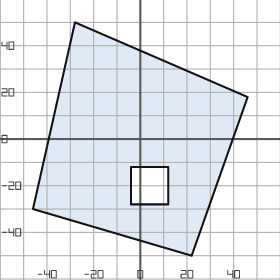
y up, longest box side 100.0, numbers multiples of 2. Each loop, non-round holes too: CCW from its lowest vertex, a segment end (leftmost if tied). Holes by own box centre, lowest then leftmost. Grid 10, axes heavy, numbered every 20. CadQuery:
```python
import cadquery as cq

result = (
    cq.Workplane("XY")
    .moveTo(22.0, -50.0)
    .lineTo(46.0, 18.0)
    .lineTo(-28.0, 50.0)
    .lineTo(-46.0, -30.0)
    .close()
    .moveTo(-4.0, -28.0)
    .lineTo(12.0, -28.0)
    .lineTo(12.0, -12.0)
    .lineTo(-4.0, -12.0)
    .close()
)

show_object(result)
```